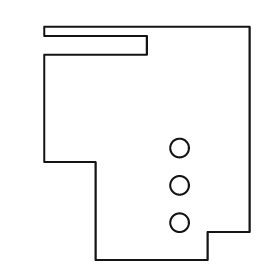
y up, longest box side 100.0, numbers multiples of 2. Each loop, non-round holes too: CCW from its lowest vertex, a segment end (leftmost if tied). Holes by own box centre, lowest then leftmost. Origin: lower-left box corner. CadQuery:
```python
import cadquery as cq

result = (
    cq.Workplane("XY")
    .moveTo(22.0, 0.0)
    .lineTo(70.0, 0.0)
    .lineTo(70.0, 12.0)
    .lineTo(88.0, 12.0)
    .lineTo(88.0, 100.0)
    .lineTo(0.0, 100.0)
    .lineTo(0.0, 96.0)
    .lineTo(44.0, 96.0)
    .lineTo(44.0, 88.0)
    .lineTo(0.0, 88.0)
    .lineTo(0.0, 42.0)
    .lineTo(22.0, 42.0)
    .close()
    .moveTo(58.0, 16.0)
    .circle(4.0)
    .moveTo(58.0, 32.0)
    .circle(4.0)
    .moveTo(58.0, 48.0)
    .circle(4.0)
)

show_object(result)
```